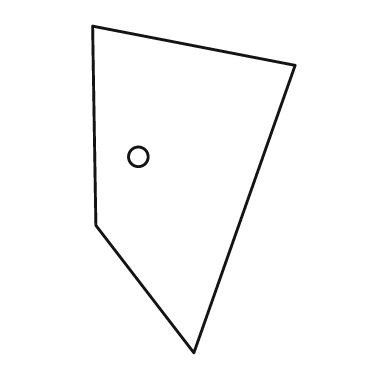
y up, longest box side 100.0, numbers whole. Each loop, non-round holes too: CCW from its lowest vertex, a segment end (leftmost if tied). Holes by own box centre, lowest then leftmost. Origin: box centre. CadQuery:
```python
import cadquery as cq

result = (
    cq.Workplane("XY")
    .moveTo(0.0, -50.0)
    .lineTo(31.0, 38.0)
    .lineTo(-31.0, 50.0)
    .lineTo(-30.0, -11.0)
    .close()
    .moveTo(-17.0, 10.0)
    .circle(3.0)
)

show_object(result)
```